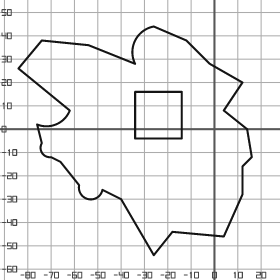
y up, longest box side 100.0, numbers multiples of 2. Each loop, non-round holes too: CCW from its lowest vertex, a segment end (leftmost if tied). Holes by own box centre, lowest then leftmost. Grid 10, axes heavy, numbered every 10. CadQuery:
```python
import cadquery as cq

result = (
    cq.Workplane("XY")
    .moveTo(-26.0, -54.0)
    .lineTo(-18.0, -44.0)
    .lineTo(4.0, -46.0)
    .lineTo(12.0, -28.0)
    .lineTo(12.0, -16.0)
    .lineTo(16.0, -12.0)
    .lineTo(14.0, 0.0)
    .lineTo(4.0, 8.0)
    .lineTo(12.0, 20.0)
    .lineTo(-2.0, 28.0)
    .lineTo(-12.0, 38.0)
    .lineTo(-26.0, 44.0)
    .threePointArc((-34.0, 38.0), (-34.0, 28.0))
    .lineTo(-54.0, 36.0)
    .lineTo(-74.0, 38.0)
    .lineTo(-84.0, 26.0)
    .lineTo(-62.0, 8.0)
    .threePointArc((-68.0, 2.0), (-76.0, 2.0))
    .lineTo(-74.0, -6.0)
    .threePointArc((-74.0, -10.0), (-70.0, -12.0))
    .lineTo(-66.0, -14.0)
    .lineTo(-58.0, -24.0)
    .threePointArc((-54.0, -30.0), (-48.0, -26.0))
    .lineTo(-40.0, -30.0)
    .close()
    .moveTo(-34.0, -4.0)
    .lineTo(-14.0, -4.0)
    .lineTo(-14.0, 16.0)
    .lineTo(-34.0, 16.0)
    .close()
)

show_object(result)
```